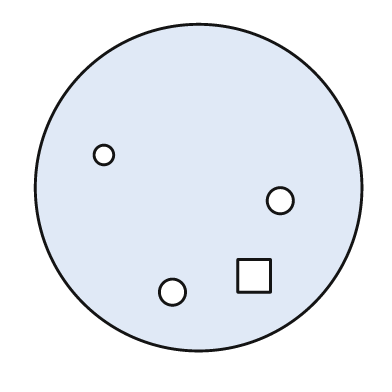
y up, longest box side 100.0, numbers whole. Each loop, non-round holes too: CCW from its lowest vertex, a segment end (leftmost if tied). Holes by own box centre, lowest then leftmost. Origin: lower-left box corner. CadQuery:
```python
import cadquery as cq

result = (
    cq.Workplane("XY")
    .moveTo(50.0, 50.0)
    .circle(50.0)
    .moveTo(42.0, 18.0)
    .circle(4.0)
    .moveTo(62.0, 18.0)
    .lineTo(72.0, 18.0)
    .lineTo(72.0, 28.0)
    .lineTo(62.0, 28.0)
    .close()
    .moveTo(75.0, 46.0)
    .circle(4.0)
    .moveTo(21.0, 60.0)
    .circle(3.0)
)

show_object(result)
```